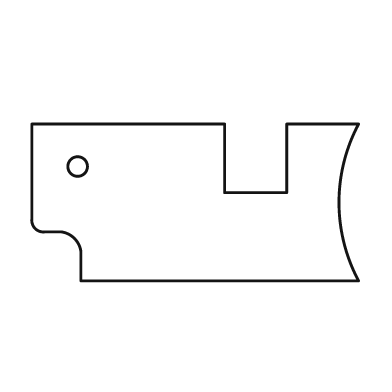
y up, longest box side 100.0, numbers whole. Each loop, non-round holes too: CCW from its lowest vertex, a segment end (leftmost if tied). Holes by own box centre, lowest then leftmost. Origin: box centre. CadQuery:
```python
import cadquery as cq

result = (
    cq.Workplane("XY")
    .moveTo(-35.0, -24.0)
    .lineTo(50.0, -24.0)
    .threePointArc((44.0, 0.0), (50.0, 24.0))
    .lineTo(28.0, 24.0)
    .lineTo(28.0, 3.0)
    .lineTo(9.0, 3.0)
    .lineTo(9.0, 24.0)
    .lineTo(-50.0, 24.0)
    .lineTo(-50.0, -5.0)
    .threePointArc((-49.0, -8.0), (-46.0, -9.0))
    .lineTo(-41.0, -9.0)
    .threePointArc((-37.0, -11.0), (-35.0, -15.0))
    .close()
    .moveTo(-36.0, 11.0)
    .circle(3.0)
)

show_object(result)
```